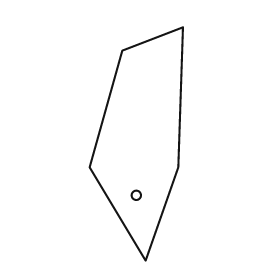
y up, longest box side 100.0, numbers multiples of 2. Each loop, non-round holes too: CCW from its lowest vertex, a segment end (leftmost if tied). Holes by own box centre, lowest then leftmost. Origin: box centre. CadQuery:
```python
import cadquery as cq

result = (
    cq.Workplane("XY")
    .moveTo(4.0, -50.0)
    .lineTo(18.0, -10.0)
    .lineTo(20.0, 50.0)
    .lineTo(-6.0, 40.0)
    .lineTo(-20.0, -10.0)
    .close()
    .moveTo(0.0, -22.0)
    .circle(2.0)
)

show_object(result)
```